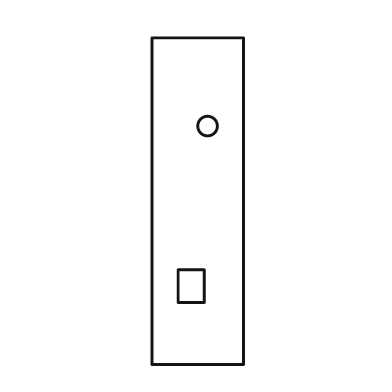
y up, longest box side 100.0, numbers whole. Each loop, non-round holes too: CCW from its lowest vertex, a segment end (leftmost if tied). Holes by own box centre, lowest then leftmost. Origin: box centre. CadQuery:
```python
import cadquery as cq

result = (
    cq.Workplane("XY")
    .moveTo(-14.0, -50.0)
    .lineTo(14.0, -50.0)
    .lineTo(14.0, 50.0)
    .lineTo(-14.0, 50.0)
    .close()
    .moveTo(-6.0, -31.0)
    .lineTo(2.0, -31.0)
    .lineTo(2.0, -21.0)
    .lineTo(-6.0, -21.0)
    .close()
    .moveTo(3.0, 23.0)
    .circle(3.0)
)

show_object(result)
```